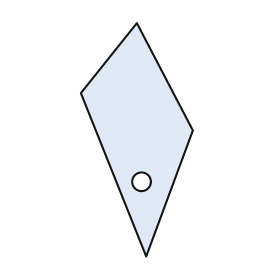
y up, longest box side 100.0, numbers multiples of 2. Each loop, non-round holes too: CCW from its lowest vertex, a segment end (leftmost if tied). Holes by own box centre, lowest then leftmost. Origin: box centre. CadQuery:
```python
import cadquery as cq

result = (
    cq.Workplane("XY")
    .moveTo(4.0, -50.0)
    .lineTo(24.0, 4.0)
    .lineTo(0.0, 50.0)
    .lineTo(-24.0, 20.0)
    .close()
    .moveTo(2.0, -18.0)
    .circle(4.0)
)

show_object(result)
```